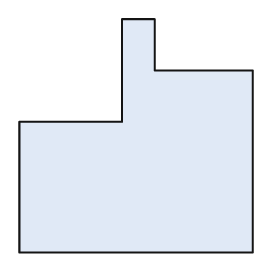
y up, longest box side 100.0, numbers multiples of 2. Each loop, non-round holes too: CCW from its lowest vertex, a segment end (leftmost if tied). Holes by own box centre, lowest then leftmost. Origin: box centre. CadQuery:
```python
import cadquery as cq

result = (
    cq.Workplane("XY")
    .moveTo(-50.0, -50.0)
    .lineTo(50.0, -50.0)
    .lineTo(50.0, 28.0)
    .lineTo(8.0, 28.0)
    .lineTo(8.0, 50.0)
    .lineTo(-6.0, 50.0)
    .lineTo(-6.0, 6.0)
    .lineTo(-50.0, 6.0)
    .close()
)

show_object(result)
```